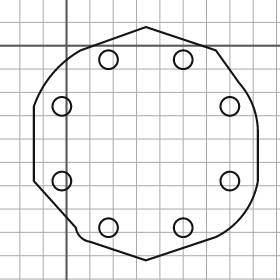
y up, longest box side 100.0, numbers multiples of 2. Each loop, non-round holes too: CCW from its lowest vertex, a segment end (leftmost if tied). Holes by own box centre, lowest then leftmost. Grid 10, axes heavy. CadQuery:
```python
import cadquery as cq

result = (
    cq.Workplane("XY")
    .moveTo(34.0, -92.0)
    .lineTo(64.0, -82.0)
    .threePointArc((76.0, -72.0), (82.0, -58.0))
    .lineTo(82.0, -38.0)
    .threePointArc((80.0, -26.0), (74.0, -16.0))
    .lineTo(64.0, -2.0)
    .lineTo(34.0, 8.0)
    .lineTo(6.0, -2.0)
    .threePointArc((-6.0, -12.0), (-14.0, -26.0))
    .lineTo(-14.0, -58.0)
    .lineTo(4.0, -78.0)
    .threePointArc((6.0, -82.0), (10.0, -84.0))
    .close()
    .moveTo(18.0, -78.0)
    .circle(4.0)
    .moveTo(50.0, -78.0)
    .circle(4.0)
    .moveTo(-2.0, -58.0)
    .circle(4.0)
    .moveTo(70.0, -58.0)
    .circle(4.0)
    .moveTo(-2.0, -26.0)
    .circle(4.0)
    .moveTo(70.0, -26.0)
    .circle(4.0)
    .moveTo(18.0, -6.0)
    .circle(4.0)
    .moveTo(50.0, -6.0)
    .circle(4.0)
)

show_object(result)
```